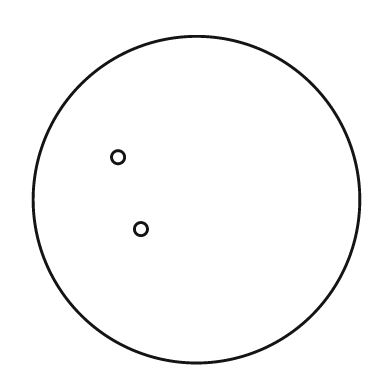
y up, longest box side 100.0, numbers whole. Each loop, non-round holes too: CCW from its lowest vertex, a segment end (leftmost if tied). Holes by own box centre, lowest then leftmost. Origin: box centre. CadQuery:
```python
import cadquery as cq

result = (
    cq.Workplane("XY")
    .moveTo(0.0, 0.0)
    .circle(50.0)
    .moveTo(-17.0, -9.0)
    .circle(2.0)
    .moveTo(-24.0, 13.0)
    .circle(2.0)
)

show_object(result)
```